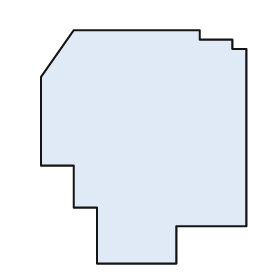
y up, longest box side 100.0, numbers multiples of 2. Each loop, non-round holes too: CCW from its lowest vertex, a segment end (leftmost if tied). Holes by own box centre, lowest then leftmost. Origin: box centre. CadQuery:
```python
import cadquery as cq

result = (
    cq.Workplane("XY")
    .moveTo(-20.0, -50.0)
    .lineTo(14.0, -50.0)
    .lineTo(14.0, -34.0)
    .lineTo(44.0, -34.0)
    .lineTo(44.0, 42.0)
    .lineTo(38.0, 42.0)
    .lineTo(38.0, 46.0)
    .lineTo(24.0, 46.0)
    .lineTo(24.0, 50.0)
    .lineTo(-30.0, 50.0)
    .lineTo(-44.0, 30.0)
    .lineTo(-44.0, -8.0)
    .lineTo(-30.0, -8.0)
    .lineTo(-30.0, -26.0)
    .lineTo(-20.0, -26.0)
    .close()
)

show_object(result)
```